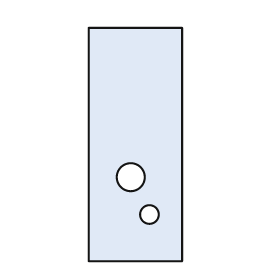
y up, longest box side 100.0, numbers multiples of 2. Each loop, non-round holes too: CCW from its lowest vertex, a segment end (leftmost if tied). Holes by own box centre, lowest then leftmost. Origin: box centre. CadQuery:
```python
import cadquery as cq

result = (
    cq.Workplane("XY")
    .moveTo(-20.0, -50.0)
    .lineTo(20.0, -50.0)
    .lineTo(20.0, 50.0)
    .lineTo(-20.0, 50.0)
    .close()
    .moveTo(6.0, -30.0)
    .circle(4.0)
    .moveTo(-2.0, -14.0)
    .circle(6.0)
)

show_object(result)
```